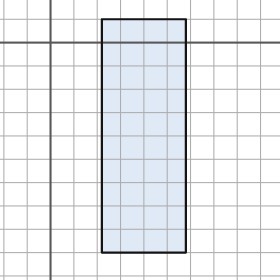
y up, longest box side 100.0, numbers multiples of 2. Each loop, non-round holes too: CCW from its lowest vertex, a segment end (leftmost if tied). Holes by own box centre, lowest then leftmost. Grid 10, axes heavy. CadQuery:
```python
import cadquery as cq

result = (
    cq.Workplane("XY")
    .moveTo(22.0, -90.0)
    .lineTo(58.0, -90.0)
    .lineTo(58.0, 10.0)
    .lineTo(22.0, 10.0)
    .close()
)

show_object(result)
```